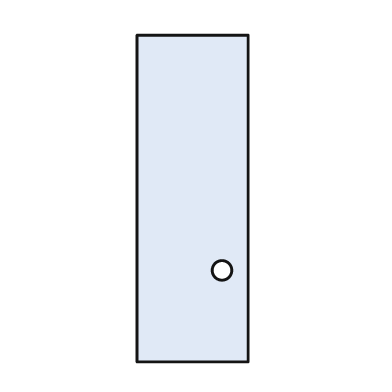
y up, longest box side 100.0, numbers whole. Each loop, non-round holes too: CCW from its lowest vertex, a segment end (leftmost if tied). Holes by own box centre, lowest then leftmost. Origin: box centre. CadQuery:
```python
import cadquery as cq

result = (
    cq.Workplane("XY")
    .moveTo(-17.0, -50.0)
    .lineTo(17.0, -50.0)
    .lineTo(17.0, 50.0)
    .lineTo(-17.0, 50.0)
    .close()
    .moveTo(9.0, -22.0)
    .circle(3.0)
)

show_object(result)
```